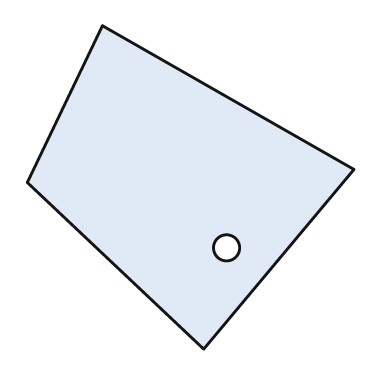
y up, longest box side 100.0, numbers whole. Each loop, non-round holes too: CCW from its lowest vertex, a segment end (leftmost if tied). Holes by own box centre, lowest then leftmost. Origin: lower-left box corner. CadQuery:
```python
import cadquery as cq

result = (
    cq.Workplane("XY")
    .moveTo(54.0, 0.0)
    .lineTo(100.0, 55.0)
    .lineTo(23.0, 99.0)
    .lineTo(0.0, 51.0)
    .close()
    .moveTo(61.0, 31.0)
    .circle(4.0)
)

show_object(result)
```